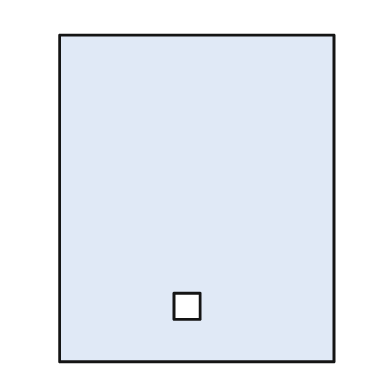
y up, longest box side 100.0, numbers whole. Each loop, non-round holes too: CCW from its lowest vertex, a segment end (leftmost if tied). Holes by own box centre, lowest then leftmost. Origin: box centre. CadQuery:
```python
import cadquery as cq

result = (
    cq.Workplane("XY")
    .moveTo(-42.0, -50.0)
    .lineTo(42.0, -50.0)
    .lineTo(42.0, 50.0)
    .lineTo(-42.0, 50.0)
    .close()
    .moveTo(-7.0, -37.0)
    .lineTo(1.0, -37.0)
    .lineTo(1.0, -29.0)
    .lineTo(-7.0, -29.0)
    .close()
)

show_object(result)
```